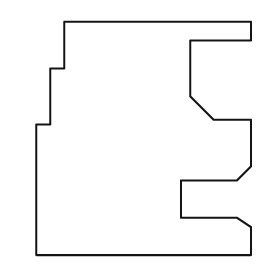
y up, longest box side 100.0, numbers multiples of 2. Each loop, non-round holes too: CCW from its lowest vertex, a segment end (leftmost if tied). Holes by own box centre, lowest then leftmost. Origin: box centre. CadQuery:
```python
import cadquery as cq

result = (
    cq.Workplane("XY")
    .moveTo(-46.0, -50.0)
    .lineTo(46.0, -50.0)
    .lineTo(46.0, -38.0)
    .lineTo(40.0, -34.0)
    .lineTo(16.0, -34.0)
    .lineTo(16.0, -18.0)
    .lineTo(40.0, -18.0)
    .lineTo(46.0, -12.0)
    .lineTo(46.0, 8.0)
    .lineTo(30.0, 8.0)
    .lineTo(20.0, 18.0)
    .lineTo(20.0, 42.0)
    .lineTo(46.0, 42.0)
    .lineTo(46.0, 50.0)
    .lineTo(-34.0, 50.0)
    .lineTo(-34.0, 30.0)
    .lineTo(-40.0, 30.0)
    .lineTo(-40.0, 6.0)
    .lineTo(-46.0, 6.0)
    .close()
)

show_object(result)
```